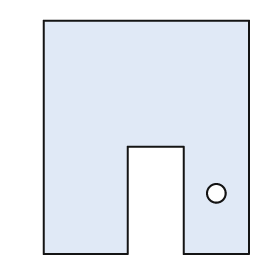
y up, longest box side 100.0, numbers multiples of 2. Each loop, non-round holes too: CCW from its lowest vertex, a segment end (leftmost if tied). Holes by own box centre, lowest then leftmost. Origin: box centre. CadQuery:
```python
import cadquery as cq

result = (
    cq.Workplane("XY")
    .moveTo(-44.0, -50.0)
    .lineTo(-8.0, -50.0)
    .lineTo(-8.0, -4.0)
    .lineTo(16.0, -4.0)
    .lineTo(16.0, -50.0)
    .lineTo(44.0, -50.0)
    .lineTo(44.0, 50.0)
    .lineTo(-44.0, 50.0)
    .close()
    .moveTo(30.0, -24.0)
    .circle(4.0)
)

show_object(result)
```